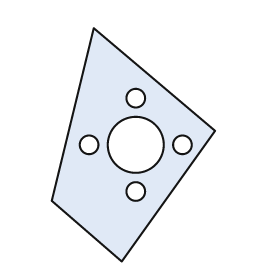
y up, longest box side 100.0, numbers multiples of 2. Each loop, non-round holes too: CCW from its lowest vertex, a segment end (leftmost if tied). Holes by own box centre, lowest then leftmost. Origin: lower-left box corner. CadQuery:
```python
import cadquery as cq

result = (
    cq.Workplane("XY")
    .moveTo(30.0, 0.0)
    .lineTo(70.0, 56.0)
    .lineTo(18.0, 100.0)
    .lineTo(0.0, 26.0)
    .close()
    .moveTo(36.0, 30.0)
    .circle(4.0)
    .moveTo(16.0, 50.0)
    .circle(4.0)
    .moveTo(36.0, 50.0)
    .circle(12.0)
    .moveTo(56.0, 50.0)
    .circle(4.0)
    .moveTo(36.0, 70.0)
    .circle(4.0)
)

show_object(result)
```